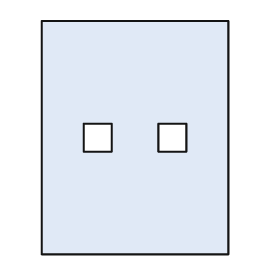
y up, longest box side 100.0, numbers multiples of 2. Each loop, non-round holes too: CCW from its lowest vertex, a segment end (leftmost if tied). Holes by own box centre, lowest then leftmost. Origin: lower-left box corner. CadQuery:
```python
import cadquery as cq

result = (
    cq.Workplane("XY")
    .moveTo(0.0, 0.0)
    .lineTo(80.0, 0.0)
    .lineTo(80.0, 100.0)
    .lineTo(0.0, 100.0)
    .close()
    .moveTo(18.0, 44.0)
    .lineTo(30.0, 44.0)
    .lineTo(30.0, 56.0)
    .lineTo(18.0, 56.0)
    .close()
    .moveTo(50.0, 44.0)
    .lineTo(62.0, 44.0)
    .lineTo(62.0, 56.0)
    .lineTo(50.0, 56.0)
    .close()
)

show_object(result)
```